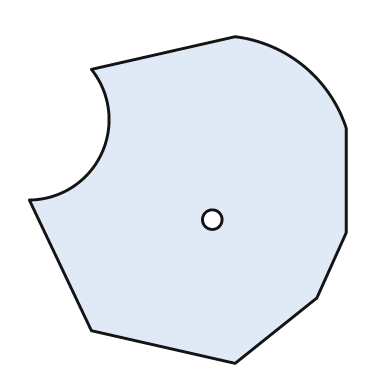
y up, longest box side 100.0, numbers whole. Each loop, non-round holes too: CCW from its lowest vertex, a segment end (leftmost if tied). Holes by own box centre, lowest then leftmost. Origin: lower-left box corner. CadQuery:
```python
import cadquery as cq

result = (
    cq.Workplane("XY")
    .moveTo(63.0, 0.0)
    .lineTo(88.0, 20.0)
    .lineTo(97.0, 40.0)
    .lineTo(97.0, 72.0)
    .threePointArc((84.0, 91.0), (63.0, 100.0))
    .lineTo(19.0, 90.0)
    .threePointArc((22.0, 64.0), (0.0, 50.0))
    .lineTo(19.0, 10.0)
    .close()
    .moveTo(56.0, 44.0)
    .circle(3.0)
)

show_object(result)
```